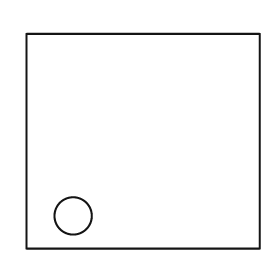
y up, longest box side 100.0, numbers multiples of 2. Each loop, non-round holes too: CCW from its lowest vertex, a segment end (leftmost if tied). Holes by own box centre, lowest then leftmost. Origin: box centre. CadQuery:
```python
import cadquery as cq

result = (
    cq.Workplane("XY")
    .moveTo(-50.0, -46.0)
    .lineTo(50.0, -46.0)
    .lineTo(50.0, 46.0)
    .lineTo(-50.0, 46.0)
    .close()
    .moveTo(-30.0, -32.0)
    .circle(8.0)
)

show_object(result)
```